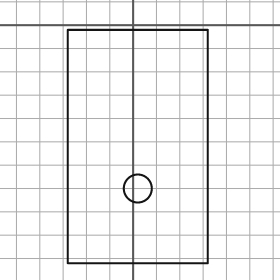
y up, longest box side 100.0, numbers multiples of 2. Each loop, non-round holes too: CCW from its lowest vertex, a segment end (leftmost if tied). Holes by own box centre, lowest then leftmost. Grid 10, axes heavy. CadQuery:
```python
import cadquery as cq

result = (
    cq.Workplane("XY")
    .moveTo(-28.0, -102.0)
    .lineTo(32.0, -102.0)
    .lineTo(32.0, -2.0)
    .lineTo(-28.0, -2.0)
    .close()
    .moveTo(2.0, -70.0)
    .circle(6.0)
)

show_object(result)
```